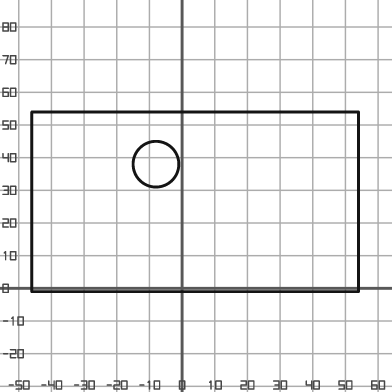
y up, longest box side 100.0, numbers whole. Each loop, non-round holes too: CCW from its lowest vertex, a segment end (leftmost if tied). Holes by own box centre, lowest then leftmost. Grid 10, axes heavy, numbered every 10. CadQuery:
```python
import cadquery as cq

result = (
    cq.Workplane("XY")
    .moveTo(-46.0, -1.0)
    .lineTo(54.0, -1.0)
    .lineTo(54.0, 54.0)
    .lineTo(-46.0, 54.0)
    .close()
    .moveTo(-8.0, 38.0)
    .circle(7.0)
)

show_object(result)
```